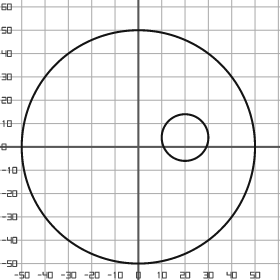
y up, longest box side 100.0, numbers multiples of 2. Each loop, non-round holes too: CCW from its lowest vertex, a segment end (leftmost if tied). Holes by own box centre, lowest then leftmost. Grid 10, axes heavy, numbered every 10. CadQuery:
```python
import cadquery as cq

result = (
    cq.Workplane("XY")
    .moveTo(0.0, 0.0)
    .circle(50.0)
    .moveTo(20.0, 4.0)
    .circle(10.0)
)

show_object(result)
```